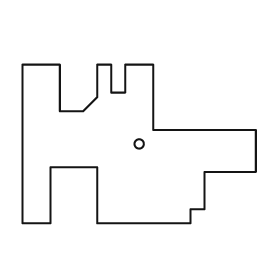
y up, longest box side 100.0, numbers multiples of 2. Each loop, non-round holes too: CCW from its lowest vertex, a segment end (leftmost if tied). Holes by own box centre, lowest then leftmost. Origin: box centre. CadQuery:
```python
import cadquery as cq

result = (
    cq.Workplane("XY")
    .moveTo(-50.0, -34.0)
    .lineTo(-38.0, -34.0)
    .lineTo(-38.0, -10.0)
    .lineTo(-18.0, -10.0)
    .lineTo(-18.0, -34.0)
    .lineTo(22.0, -34.0)
    .lineTo(22.0, -28.0)
    .lineTo(28.0, -28.0)
    .lineTo(28.0, -12.0)
    .lineTo(50.0, -12.0)
    .lineTo(50.0, 6.0)
    .lineTo(6.0, 6.0)
    .lineTo(6.0, 34.0)
    .lineTo(-6.0, 34.0)
    .lineTo(-6.0, 22.0)
    .lineTo(-12.0, 22.0)
    .lineTo(-12.0, 34.0)
    .lineTo(-18.0, 34.0)
    .lineTo(-18.0, 20.0)
    .lineTo(-24.0, 14.0)
    .lineTo(-34.0, 14.0)
    .lineTo(-34.0, 34.0)
    .lineTo(-50.0, 34.0)
    .close()
    .moveTo(0.0, 0.0)
    .circle(2.0)
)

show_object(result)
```